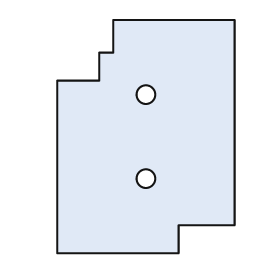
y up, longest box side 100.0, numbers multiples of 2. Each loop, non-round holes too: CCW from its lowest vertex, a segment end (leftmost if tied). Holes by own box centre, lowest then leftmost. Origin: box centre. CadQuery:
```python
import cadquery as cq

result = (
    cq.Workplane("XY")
    .moveTo(-38.0, -50.0)
    .lineTo(14.0, -50.0)
    .lineTo(14.0, -38.0)
    .lineTo(38.0, -38.0)
    .lineTo(38.0, 50.0)
    .lineTo(-14.0, 50.0)
    .lineTo(-14.0, 36.0)
    .lineTo(-20.0, 36.0)
    .lineTo(-20.0, 24.0)
    .lineTo(-38.0, 24.0)
    .close()
    .moveTo(0.0, -18.0)
    .circle(4.0)
    .moveTo(0.0, 18.0)
    .circle(4.0)
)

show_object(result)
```